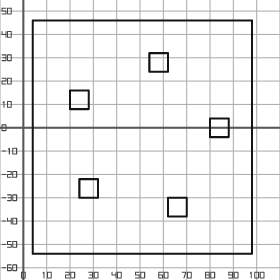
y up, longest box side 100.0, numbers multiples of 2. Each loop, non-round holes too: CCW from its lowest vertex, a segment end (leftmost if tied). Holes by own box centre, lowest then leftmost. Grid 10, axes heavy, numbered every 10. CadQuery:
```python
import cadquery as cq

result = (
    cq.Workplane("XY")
    .moveTo(4.0, -54.0)
    .lineTo(98.0, -54.0)
    .lineTo(98.0, 46.0)
    .lineTo(4.0, 46.0)
    .close()
    .moveTo(62.0, -38.0)
    .lineTo(70.0, -38.0)
    .lineTo(70.0, -30.0)
    .lineTo(62.0, -30.0)
    .close()
    .moveTo(24.0, -30.0)
    .lineTo(32.0, -30.0)
    .lineTo(32.0, -22.0)
    .lineTo(24.0, -22.0)
    .close()
    .moveTo(80.0, -4.0)
    .lineTo(88.0, -4.0)
    .lineTo(88.0, 4.0)
    .lineTo(80.0, 4.0)
    .close()
    .moveTo(20.0, 8.0)
    .lineTo(28.0, 8.0)
    .lineTo(28.0, 16.0)
    .lineTo(20.0, 16.0)
    .close()
    .moveTo(54.0, 24.0)
    .lineTo(62.0, 24.0)
    .lineTo(62.0, 32.0)
    .lineTo(54.0, 32.0)
    .close()
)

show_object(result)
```